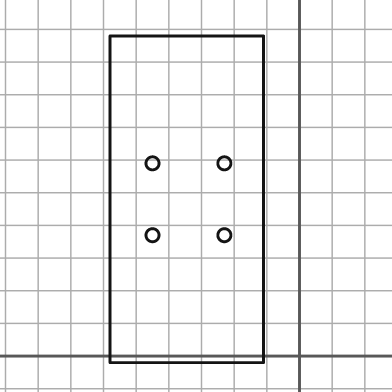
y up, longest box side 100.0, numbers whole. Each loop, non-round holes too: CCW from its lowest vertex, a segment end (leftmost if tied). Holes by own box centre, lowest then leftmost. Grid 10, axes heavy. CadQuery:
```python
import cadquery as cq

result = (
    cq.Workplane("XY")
    .moveTo(-58.0, -2.0)
    .lineTo(-11.0, -2.0)
    .lineTo(-11.0, 98.0)
    .lineTo(-58.0, 98.0)
    .close()
    .moveTo(-45.0, 37.0)
    .circle(2.0)
    .moveTo(-23.0, 37.0)
    .circle(2.0)
    .moveTo(-45.0, 59.0)
    .circle(2.0)
    .moveTo(-23.0, 59.0)
    .circle(2.0)
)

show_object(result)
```